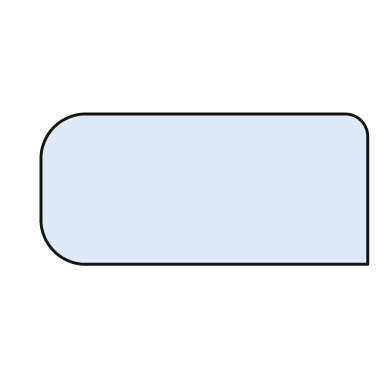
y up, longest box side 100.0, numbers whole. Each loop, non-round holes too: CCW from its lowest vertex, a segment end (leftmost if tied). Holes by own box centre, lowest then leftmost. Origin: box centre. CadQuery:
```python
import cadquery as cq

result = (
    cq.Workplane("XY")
    .moveTo(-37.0, -23.0)
    .lineTo(50.0, -23.0)
    .lineTo(50.0, 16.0)
    .threePointArc((48.0, 21.0), (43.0, 23.0))
    .lineTo(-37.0, 23.0)
    .threePointArc((-46.0, 19.0), (-50.0, 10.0))
    .lineTo(-50.0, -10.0)
    .threePointArc((-46.0, -19.0), (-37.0, -23.0))
    .close()
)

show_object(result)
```